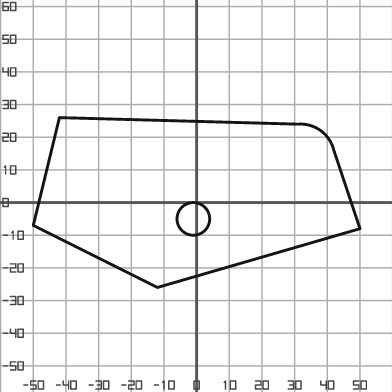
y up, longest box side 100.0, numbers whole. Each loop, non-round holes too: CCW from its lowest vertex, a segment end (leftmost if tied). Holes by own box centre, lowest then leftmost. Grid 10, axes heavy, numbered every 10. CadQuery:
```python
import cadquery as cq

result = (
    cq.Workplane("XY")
    .moveTo(-12.0, -26.0)
    .lineTo(50.0, -8.0)
    .lineTo(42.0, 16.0)
    .threePointArc((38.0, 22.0), (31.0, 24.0))
    .lineTo(-42.0, 26.0)
    .lineTo(-50.0, -7.0)
    .close()
    .moveTo(-1.0, -5.0)
    .circle(5.0)
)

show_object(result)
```